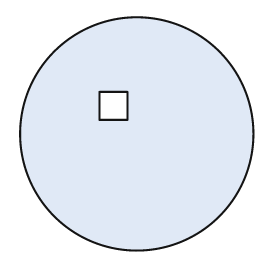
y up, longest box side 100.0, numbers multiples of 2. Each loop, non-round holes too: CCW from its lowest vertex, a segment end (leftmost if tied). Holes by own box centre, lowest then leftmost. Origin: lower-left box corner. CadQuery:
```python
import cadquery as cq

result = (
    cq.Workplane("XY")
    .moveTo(50.0, 50.0)
    .circle(50.0)
    .moveTo(34.0, 56.0)
    .lineTo(46.0, 56.0)
    .lineTo(46.0, 68.0)
    .lineTo(34.0, 68.0)
    .close()
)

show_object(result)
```